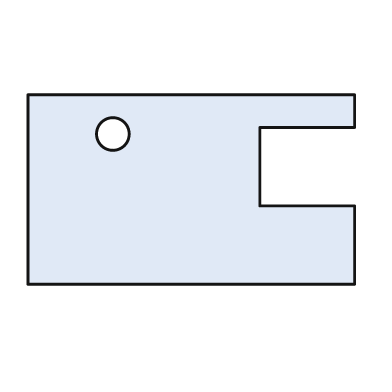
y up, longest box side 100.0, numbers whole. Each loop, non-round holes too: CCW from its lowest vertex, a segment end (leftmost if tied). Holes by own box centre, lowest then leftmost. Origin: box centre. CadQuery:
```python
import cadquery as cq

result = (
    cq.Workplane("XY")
    .moveTo(-50.0, -29.0)
    .lineTo(50.0, -29.0)
    .lineTo(50.0, -5.0)
    .lineTo(21.0, -5.0)
    .lineTo(21.0, 19.0)
    .lineTo(50.0, 19.0)
    .lineTo(50.0, 29.0)
    .lineTo(-50.0, 29.0)
    .close()
    .moveTo(-24.0, 17.0)
    .circle(5.0)
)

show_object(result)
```